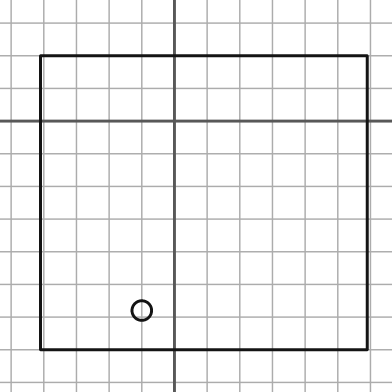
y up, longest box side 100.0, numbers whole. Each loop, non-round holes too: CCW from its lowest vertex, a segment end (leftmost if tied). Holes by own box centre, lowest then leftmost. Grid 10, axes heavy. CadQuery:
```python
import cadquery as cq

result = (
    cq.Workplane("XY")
    .moveTo(-41.0, -70.0)
    .lineTo(59.0, -70.0)
    .lineTo(59.0, 20.0)
    .lineTo(-41.0, 20.0)
    .close()
    .moveTo(-10.0, -58.0)
    .circle(3.0)
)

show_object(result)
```